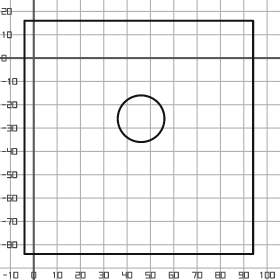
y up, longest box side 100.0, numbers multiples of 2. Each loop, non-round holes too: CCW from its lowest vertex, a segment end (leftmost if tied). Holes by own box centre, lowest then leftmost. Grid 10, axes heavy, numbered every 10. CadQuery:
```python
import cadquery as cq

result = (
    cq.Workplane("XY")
    .moveTo(-4.0, -84.0)
    .lineTo(94.0, -84.0)
    .lineTo(94.0, 16.0)
    .lineTo(-4.0, 16.0)
    .close()
    .moveTo(46.0, -26.0)
    .circle(10.0)
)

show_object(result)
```